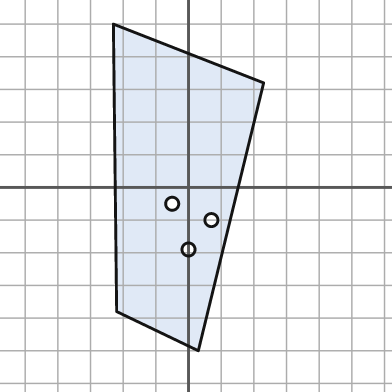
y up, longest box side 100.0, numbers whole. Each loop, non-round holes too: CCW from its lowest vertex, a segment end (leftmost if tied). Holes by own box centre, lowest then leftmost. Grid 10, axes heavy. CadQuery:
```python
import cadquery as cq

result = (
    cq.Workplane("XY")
    .moveTo(3.0, -50.0)
    .lineTo(23.0, 32.0)
    .lineTo(-23.0, 50.0)
    .lineTo(-22.0, -38.0)
    .close()
    .moveTo(0.0, -19.0)
    .circle(2.0)
    .moveTo(7.0, -10.0)
    .circle(2.0)
    .moveTo(-5.0, -5.0)
    .circle(2.0)
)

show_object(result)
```